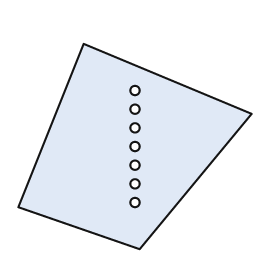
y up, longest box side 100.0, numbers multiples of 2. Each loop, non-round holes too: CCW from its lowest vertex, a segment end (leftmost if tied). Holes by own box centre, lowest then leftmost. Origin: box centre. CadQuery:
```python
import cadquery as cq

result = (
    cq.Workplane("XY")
    .moveTo(2.0, -44.0)
    .lineTo(50.0, 14.0)
    .lineTo(-22.0, 44.0)
    .lineTo(-50.0, -26.0)
    .close()
    .moveTo(0.0, -24.0)
    .circle(2.0)
    .moveTo(0.0, -16.0)
    .circle(2.0)
    .moveTo(0.0, -8.0)
    .circle(2.0)
    .moveTo(0.0, 0.0)
    .circle(2.0)
    .moveTo(0.0, 8.0)
    .circle(2.0)
    .moveTo(0.0, 16.0)
    .circle(2.0)
    .moveTo(0.0, 24.0)
    .circle(2.0)
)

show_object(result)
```